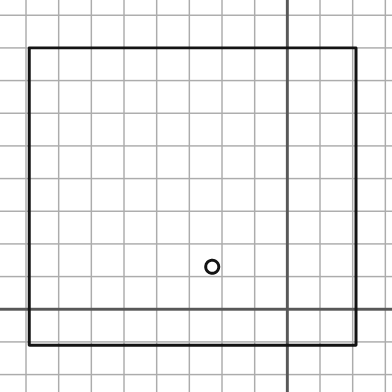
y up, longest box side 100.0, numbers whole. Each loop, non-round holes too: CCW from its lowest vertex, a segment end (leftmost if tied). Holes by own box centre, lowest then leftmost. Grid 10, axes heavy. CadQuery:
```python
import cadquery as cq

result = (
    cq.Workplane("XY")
    .moveTo(-79.0, -11.0)
    .lineTo(21.0, -11.0)
    .lineTo(21.0, 80.0)
    .lineTo(-79.0, 80.0)
    .close()
    .moveTo(-23.0, 13.0)
    .circle(2.0)
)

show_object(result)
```